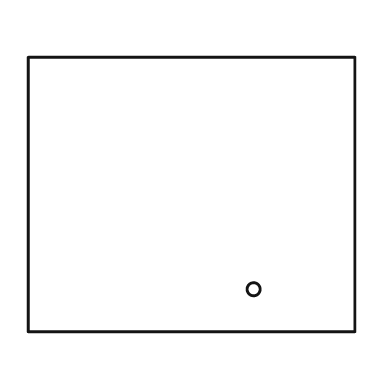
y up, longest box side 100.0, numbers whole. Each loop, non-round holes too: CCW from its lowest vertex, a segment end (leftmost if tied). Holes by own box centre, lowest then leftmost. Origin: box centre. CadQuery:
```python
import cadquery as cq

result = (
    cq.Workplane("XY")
    .moveTo(-50.0, -42.0)
    .lineTo(50.0, -42.0)
    .lineTo(50.0, 42.0)
    .lineTo(-50.0, 42.0)
    .close()
    .moveTo(19.0, -29.0)
    .circle(2.0)
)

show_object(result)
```